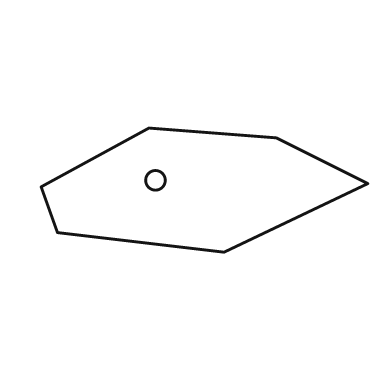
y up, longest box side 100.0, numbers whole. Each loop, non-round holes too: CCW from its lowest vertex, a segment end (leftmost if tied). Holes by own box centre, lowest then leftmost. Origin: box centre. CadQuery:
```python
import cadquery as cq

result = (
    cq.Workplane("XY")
    .moveTo(6.0, -19.0)
    .lineTo(50.0, 2.0)
    .lineTo(22.0, 16.0)
    .lineTo(-17.0, 19.0)
    .lineTo(-50.0, 1.0)
    .lineTo(-45.0, -13.0)
    .close()
    .moveTo(-15.0, 3.0)
    .circle(3.0)
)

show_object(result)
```